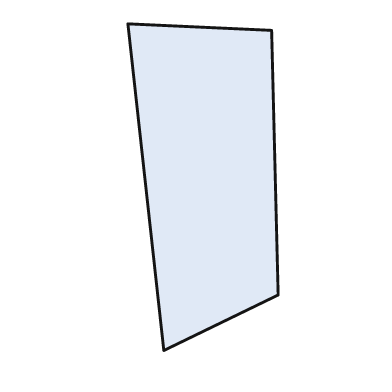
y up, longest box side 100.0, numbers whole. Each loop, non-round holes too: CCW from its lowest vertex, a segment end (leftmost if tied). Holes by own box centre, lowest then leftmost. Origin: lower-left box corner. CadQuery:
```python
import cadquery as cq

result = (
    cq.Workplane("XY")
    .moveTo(11.0, 0.0)
    .lineTo(46.0, 17.0)
    .lineTo(44.0, 98.0)
    .lineTo(0.0, 100.0)
    .close()
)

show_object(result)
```